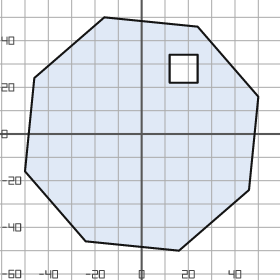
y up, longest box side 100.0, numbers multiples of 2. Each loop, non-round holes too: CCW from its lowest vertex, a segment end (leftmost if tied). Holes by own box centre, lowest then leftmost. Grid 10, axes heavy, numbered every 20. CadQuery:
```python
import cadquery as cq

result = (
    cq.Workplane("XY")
    .moveTo(16.0, -50.0)
    .lineTo(46.0, -24.0)
    .lineTo(50.0, 16.0)
    .lineTo(24.0, 46.0)
    .lineTo(-16.0, 50.0)
    .lineTo(-46.0, 24.0)
    .lineTo(-50.0, -16.0)
    .lineTo(-24.0, -46.0)
    .close()
    .moveTo(12.0, 22.0)
    .lineTo(24.0, 22.0)
    .lineTo(24.0, 34.0)
    .lineTo(12.0, 34.0)
    .close()
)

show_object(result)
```